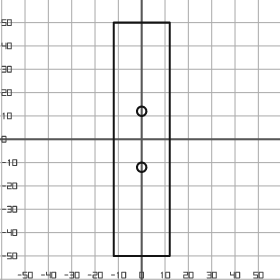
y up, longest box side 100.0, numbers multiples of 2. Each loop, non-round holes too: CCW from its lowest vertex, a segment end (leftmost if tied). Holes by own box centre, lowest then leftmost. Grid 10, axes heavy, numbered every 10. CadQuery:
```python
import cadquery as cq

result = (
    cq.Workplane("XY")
    .moveTo(-12.0, -50.0)
    .lineTo(12.0, -50.0)
    .lineTo(12.0, 50.0)
    .lineTo(-12.0, 50.0)
    .close()
    .moveTo(0.0, -12.0)
    .circle(2.0)
    .moveTo(0.0, 12.0)
    .circle(2.0)
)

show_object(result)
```